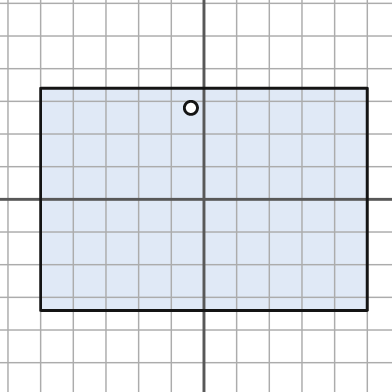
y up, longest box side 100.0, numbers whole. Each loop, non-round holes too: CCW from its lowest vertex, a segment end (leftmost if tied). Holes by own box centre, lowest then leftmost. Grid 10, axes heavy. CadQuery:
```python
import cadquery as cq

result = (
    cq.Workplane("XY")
    .moveTo(-50.0, -34.0)
    .lineTo(50.0, -34.0)
    .lineTo(50.0, 34.0)
    .lineTo(-50.0, 34.0)
    .close()
    .moveTo(-4.0, 28.0)
    .circle(2.0)
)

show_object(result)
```